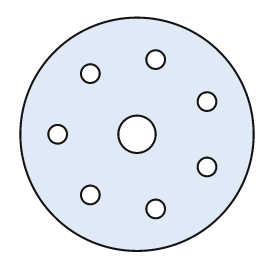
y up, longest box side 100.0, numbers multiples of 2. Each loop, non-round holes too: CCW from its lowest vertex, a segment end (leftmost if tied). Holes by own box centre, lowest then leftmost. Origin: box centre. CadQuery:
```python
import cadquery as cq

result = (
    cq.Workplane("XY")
    .moveTo(0.0, 0.0)
    .circle(50.0)
    .moveTo(8.0, -32.0)
    .circle(4.0)
    .moveTo(-20.0, -26.0)
    .circle(4.0)
    .moveTo(30.0, -14.0)
    .circle(4.0)
    .moveTo(-34.0, 0.0)
    .circle(4.0)
    .moveTo(0.0, 0.0)
    .circle(8.0)
    .moveTo(30.0, 14.0)
    .circle(4.0)
    .moveTo(-20.0, 26.0)
    .circle(4.0)
    .moveTo(8.0, 32.0)
    .circle(4.0)
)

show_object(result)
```